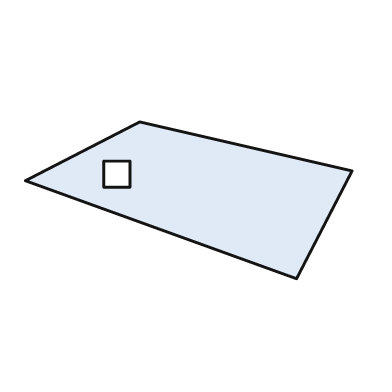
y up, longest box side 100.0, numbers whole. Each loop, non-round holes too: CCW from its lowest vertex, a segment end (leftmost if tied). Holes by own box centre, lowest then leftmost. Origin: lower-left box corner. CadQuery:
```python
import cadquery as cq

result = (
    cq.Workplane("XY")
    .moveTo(83.0, 0.0)
    .lineTo(100.0, 33.0)
    .lineTo(35.0, 48.0)
    .lineTo(0.0, 30.0)
    .close()
    .moveTo(24.0, 28.0)
    .lineTo(32.0, 28.0)
    .lineTo(32.0, 36.0)
    .lineTo(24.0, 36.0)
    .close()
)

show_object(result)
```